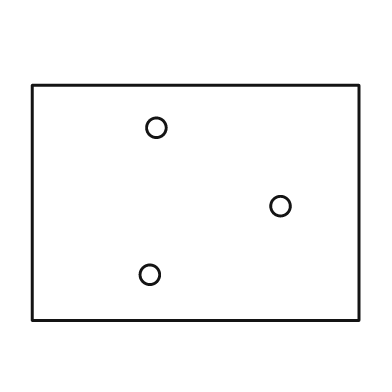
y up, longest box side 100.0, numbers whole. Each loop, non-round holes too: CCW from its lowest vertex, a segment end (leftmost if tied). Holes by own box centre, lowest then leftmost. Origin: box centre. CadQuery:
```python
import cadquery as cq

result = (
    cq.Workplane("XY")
    .moveTo(-50.0, -36.0)
    .lineTo(50.0, -36.0)
    .lineTo(50.0, 36.0)
    .lineTo(-50.0, 36.0)
    .close()
    .moveTo(-14.0, -22.0)
    .circle(3.0)
    .moveTo(26.0, -1.0)
    .circle(3.0)
    .moveTo(-12.0, 23.0)
    .circle(3.0)
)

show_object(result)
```